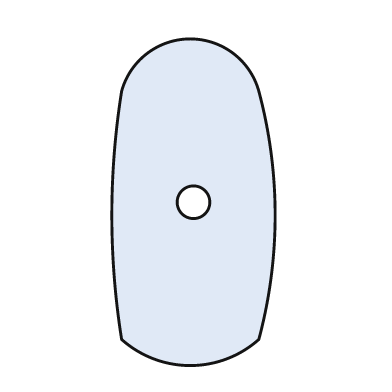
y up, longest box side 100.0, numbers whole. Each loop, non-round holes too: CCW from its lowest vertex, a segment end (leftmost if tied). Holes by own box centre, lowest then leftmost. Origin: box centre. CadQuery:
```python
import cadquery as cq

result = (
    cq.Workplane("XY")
    .moveTo(-22.0, -42.0)
    .threePointArc((-1.0, -50.0), (20.0, -42.0))
    .threePointArc((25.0, -4.0), (20.0, 34.0))
    .threePointArc((-1.0, 50.0), (-22.0, 34.0))
    .threePointArc((-25.0, -4.0), (-22.0, -42.0))
    .close()
    .moveTo(0.0, 0.0)
    .circle(5.0)
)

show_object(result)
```